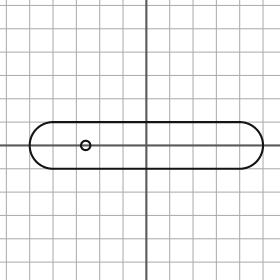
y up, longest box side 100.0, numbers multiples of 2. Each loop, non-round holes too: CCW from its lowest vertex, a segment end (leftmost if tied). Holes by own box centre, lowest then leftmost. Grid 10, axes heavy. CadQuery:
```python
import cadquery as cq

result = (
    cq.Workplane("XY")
    .moveTo(-40.0, -10.0)
    .lineTo(40.0, -10.0)
    .threePointArc((50.0, 0.0), (40.0, 10.0))
    .lineTo(-40.0, 10.0)
    .threePointArc((-50.0, 0.0), (-40.0, -10.0))
    .close()
    .moveTo(-26.0, 0.0)
    .circle(2.0)
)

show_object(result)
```